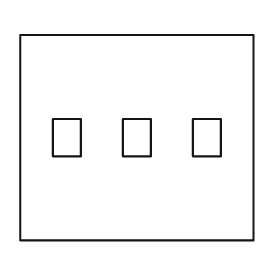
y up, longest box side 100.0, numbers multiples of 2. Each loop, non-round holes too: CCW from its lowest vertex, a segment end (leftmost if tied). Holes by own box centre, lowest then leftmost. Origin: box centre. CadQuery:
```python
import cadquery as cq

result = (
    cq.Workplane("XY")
    .moveTo(-50.0, -44.0)
    .lineTo(50.0, -44.0)
    .lineTo(50.0, 44.0)
    .lineTo(-50.0, 44.0)
    .close()
    .moveTo(-36.0, -8.0)
    .lineTo(-24.0, -8.0)
    .lineTo(-24.0, 8.0)
    .lineTo(-36.0, 8.0)
    .close()
    .moveTo(-6.0, -8.0)
    .lineTo(6.0, -8.0)
    .lineTo(6.0, 8.0)
    .lineTo(-6.0, 8.0)
    .close()
    .moveTo(24.0, -8.0)
    .lineTo(36.0, -8.0)
    .lineTo(36.0, 8.0)
    .lineTo(24.0, 8.0)
    .close()
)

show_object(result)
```